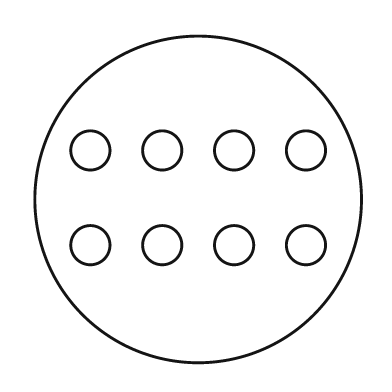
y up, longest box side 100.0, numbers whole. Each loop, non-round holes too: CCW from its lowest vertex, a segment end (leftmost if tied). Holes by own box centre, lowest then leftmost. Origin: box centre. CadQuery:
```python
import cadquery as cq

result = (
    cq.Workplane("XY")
    .moveTo(0.0, 0.0)
    .circle(50.0)
    .moveTo(-33.0, -14.0)
    .circle(6.0)
    .moveTo(-11.0, -14.0)
    .circle(6.0)
    .moveTo(11.0, -14.0)
    .circle(6.0)
    .moveTo(33.0, -14.0)
    .circle(6.0)
    .moveTo(-33.0, 15.0)
    .circle(6.0)
    .moveTo(-11.0, 15.0)
    .circle(6.0)
    .moveTo(11.0, 15.0)
    .circle(6.0)
    .moveTo(33.0, 15.0)
    .circle(6.0)
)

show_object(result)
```